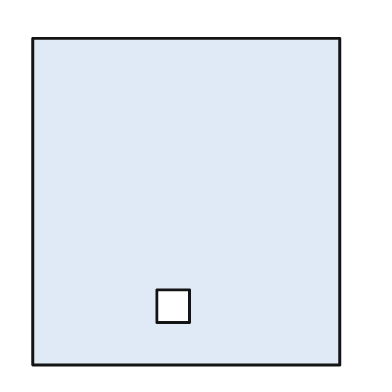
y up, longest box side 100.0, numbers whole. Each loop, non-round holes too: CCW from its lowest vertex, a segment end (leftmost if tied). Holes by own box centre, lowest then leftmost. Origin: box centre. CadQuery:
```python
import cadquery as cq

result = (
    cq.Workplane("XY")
    .moveTo(-47.0, -50.0)
    .lineTo(47.0, -50.0)
    .lineTo(47.0, 50.0)
    .lineTo(-47.0, 50.0)
    .close()
    .moveTo(-9.0, -37.0)
    .lineTo(1.0, -37.0)
    .lineTo(1.0, -27.0)
    .lineTo(-9.0, -27.0)
    .close()
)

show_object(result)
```